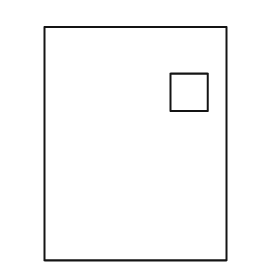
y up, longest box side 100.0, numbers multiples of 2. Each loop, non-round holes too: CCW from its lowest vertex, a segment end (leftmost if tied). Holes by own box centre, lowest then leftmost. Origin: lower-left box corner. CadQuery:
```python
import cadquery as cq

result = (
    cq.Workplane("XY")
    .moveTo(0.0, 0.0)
    .lineTo(78.0, 0.0)
    .lineTo(78.0, 100.0)
    .lineTo(0.0, 100.0)
    .close()
    .moveTo(54.0, 64.0)
    .lineTo(70.0, 64.0)
    .lineTo(70.0, 80.0)
    .lineTo(54.0, 80.0)
    .close()
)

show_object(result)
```